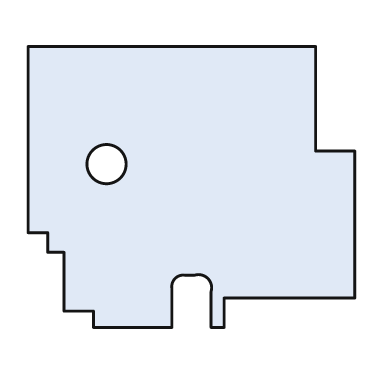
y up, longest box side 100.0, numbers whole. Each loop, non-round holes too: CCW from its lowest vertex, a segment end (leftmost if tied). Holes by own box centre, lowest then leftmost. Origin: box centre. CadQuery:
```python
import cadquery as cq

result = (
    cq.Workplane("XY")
    .moveTo(-30.0, -43.0)
    .lineTo(-6.0, -43.0)
    .lineTo(-6.0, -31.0)
    .threePointArc((-5.0, -28.0), (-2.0, -27.0))
    .lineTo(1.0, -27.0)
    .threePointArc((5.0, -28.0), (6.0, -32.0))
    .lineTo(6.0, -43.0)
    .lineTo(10.0, -43.0)
    .lineTo(10.0, -34.0)
    .lineTo(50.0, -34.0)
    .lineTo(50.0, 11.0)
    .lineTo(38.0, 11.0)
    .lineTo(38.0, 43.0)
    .lineTo(-50.0, 43.0)
    .lineTo(-50.0, -14.0)
    .lineTo(-44.0, -14.0)
    .lineTo(-44.0, -20.0)
    .lineTo(-39.0, -20.0)
    .lineTo(-39.0, -38.0)
    .lineTo(-30.0, -38.0)
    .close()
    .moveTo(-26.0, 7.0)
    .circle(6.0)
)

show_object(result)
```